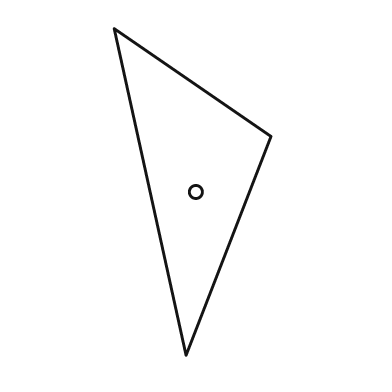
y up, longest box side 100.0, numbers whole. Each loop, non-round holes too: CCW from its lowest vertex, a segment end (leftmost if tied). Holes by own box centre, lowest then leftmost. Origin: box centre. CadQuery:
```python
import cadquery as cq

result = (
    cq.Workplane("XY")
    .moveTo(-2.0, -50.0)
    .lineTo(24.0, 17.0)
    .lineTo(-24.0, 50.0)
    .close()
    .moveTo(1.0, 0.0)
    .circle(2.0)
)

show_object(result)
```